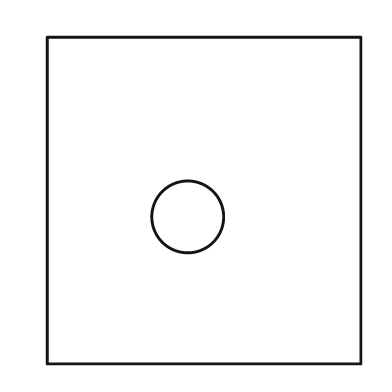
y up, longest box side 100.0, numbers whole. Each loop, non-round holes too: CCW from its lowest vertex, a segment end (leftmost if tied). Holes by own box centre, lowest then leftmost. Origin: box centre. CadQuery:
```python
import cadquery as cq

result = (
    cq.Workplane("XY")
    .moveTo(-48.0, -50.0)
    .lineTo(48.0, -50.0)
    .lineTo(48.0, 50.0)
    .lineTo(-48.0, 50.0)
    .close()
    .moveTo(-5.0, -5.0)
    .circle(11.0)
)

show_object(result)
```